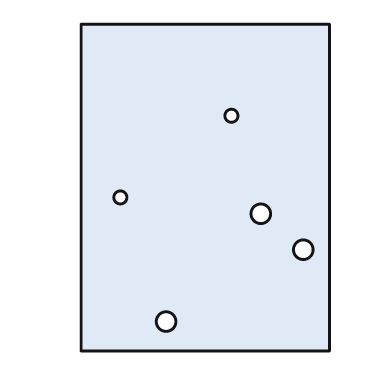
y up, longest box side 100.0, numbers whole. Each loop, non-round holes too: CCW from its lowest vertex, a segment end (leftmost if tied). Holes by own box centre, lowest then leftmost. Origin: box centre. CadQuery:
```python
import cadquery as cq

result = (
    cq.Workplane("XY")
    .moveTo(-38.0, -50.0)
    .lineTo(38.0, -50.0)
    .lineTo(38.0, 50.0)
    .lineTo(-38.0, 50.0)
    .close()
    .moveTo(-12.0, -41.0)
    .circle(3.0)
    .moveTo(30.0, -19.0)
    .circle(3.0)
    .moveTo(17.0, -8.0)
    .circle(3.0)
    .moveTo(-26.0, -3.0)
    .circle(2.0)
    .moveTo(8.0, 22.0)
    .circle(2.0)
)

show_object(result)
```